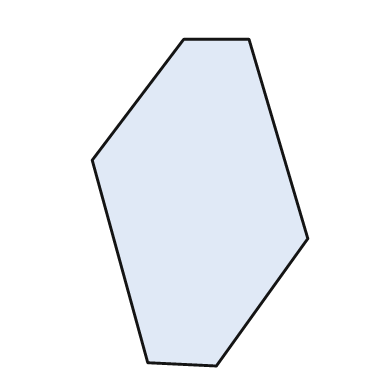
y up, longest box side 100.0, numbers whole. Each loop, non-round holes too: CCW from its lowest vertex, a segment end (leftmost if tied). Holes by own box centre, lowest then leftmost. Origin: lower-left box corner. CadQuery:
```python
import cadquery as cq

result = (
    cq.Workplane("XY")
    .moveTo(38.0, 0.0)
    .lineTo(66.0, 39.0)
    .lineTo(48.0, 100.0)
    .lineTo(28.0, 100.0)
    .lineTo(0.0, 63.0)
    .lineTo(17.0, 1.0)
    .close()
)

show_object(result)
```